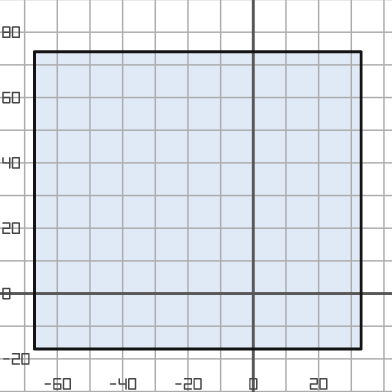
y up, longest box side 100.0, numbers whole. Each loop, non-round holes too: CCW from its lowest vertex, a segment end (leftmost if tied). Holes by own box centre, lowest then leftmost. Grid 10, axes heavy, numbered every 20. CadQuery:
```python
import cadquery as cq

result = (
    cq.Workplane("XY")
    .moveTo(-67.0, -17.0)
    .lineTo(33.0, -17.0)
    .lineTo(33.0, 74.0)
    .lineTo(-67.0, 74.0)
    .close()
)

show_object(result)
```